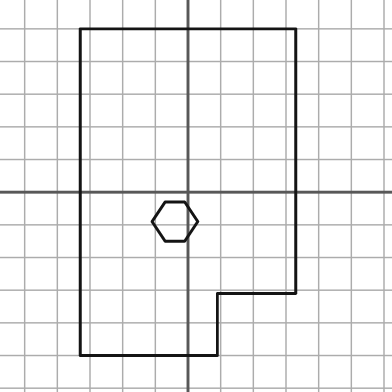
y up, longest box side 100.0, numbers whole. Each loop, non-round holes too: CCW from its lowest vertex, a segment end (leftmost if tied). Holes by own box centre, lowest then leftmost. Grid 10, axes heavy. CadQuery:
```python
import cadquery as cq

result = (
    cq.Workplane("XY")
    .moveTo(-33.0, -50.0)
    .lineTo(9.0, -50.0)
    .lineTo(9.0, -31.0)
    .lineTo(33.0, -31.0)
    .lineTo(33.0, 50.0)
    .lineTo(-33.0, 50.0)
    .close()
    .moveTo(-7.0, -15.0)
    .lineTo(-1.0, -15.0)
    .lineTo(3.0, -9.0)
    .lineTo(-1.0, -3.0)
    .lineTo(-7.0, -3.0)
    .lineTo(-11.0, -9.0)
    .close()
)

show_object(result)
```